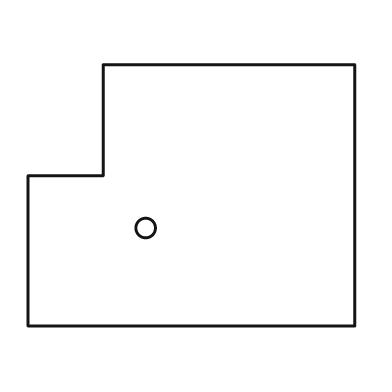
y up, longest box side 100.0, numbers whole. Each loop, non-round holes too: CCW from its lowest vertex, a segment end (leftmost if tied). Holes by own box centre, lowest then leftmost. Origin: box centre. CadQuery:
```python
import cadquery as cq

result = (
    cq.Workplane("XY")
    .moveTo(-50.0, -40.0)
    .lineTo(50.0, -40.0)
    .lineTo(50.0, 40.0)
    .lineTo(-27.0, 40.0)
    .lineTo(-27.0, 6.0)
    .lineTo(-50.0, 6.0)
    .close()
    .moveTo(-14.0, -10.0)
    .circle(3.0)
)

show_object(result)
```